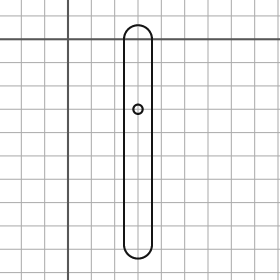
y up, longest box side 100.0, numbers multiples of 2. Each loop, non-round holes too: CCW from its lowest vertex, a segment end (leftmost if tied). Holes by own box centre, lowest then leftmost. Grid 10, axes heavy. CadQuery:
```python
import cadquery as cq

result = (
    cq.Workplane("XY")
    .moveTo(24.0, -88.0)
    .threePointArc((30.0, -94.0), (36.0, -88.0))
    .lineTo(36.0, 0.0)
    .threePointArc((30.0, 6.0), (24.0, 0.0))
    .close()
    .moveTo(30.0, -30.0)
    .circle(2.0)
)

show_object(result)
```